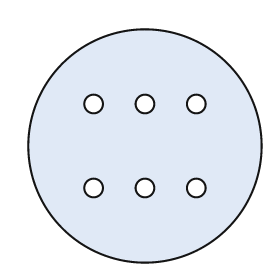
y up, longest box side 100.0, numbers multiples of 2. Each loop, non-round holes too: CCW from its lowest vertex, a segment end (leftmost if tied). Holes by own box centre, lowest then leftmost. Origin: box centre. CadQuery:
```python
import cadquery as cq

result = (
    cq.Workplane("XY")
    .moveTo(0.0, 0.0)
    .circle(50.0)
    .moveTo(-22.0, -18.0)
    .circle(4.0)
    .moveTo(0.0, -18.0)
    .circle(4.0)
    .moveTo(22.0, -18.0)
    .circle(4.0)
    .moveTo(-22.0, 18.0)
    .circle(4.0)
    .moveTo(0.0, 18.0)
    .circle(4.0)
    .moveTo(22.0, 18.0)
    .circle(4.0)
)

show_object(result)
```